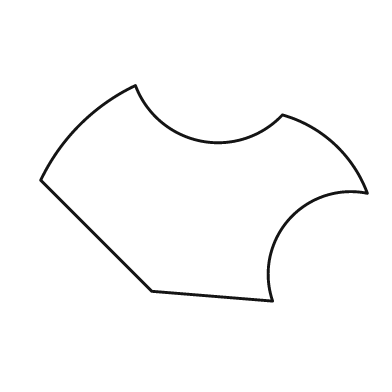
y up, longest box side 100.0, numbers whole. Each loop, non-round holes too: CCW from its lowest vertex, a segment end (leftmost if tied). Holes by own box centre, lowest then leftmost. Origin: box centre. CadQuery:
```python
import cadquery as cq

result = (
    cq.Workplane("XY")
    .moveTo(21.0, -33.0)
    .threePointArc((26.0, -8.0), (50.0, 0.0))
    .threePointArc((40.0, 15.0), (24.0, 24.0))
    .threePointArc((-1.0, 16.0), (-21.0, 33.0))
    .threePointArc((-38.0, 21.0), (-50.0, 4.0))
    .lineTo(-16.0, -30.0)
    .close()
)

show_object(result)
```